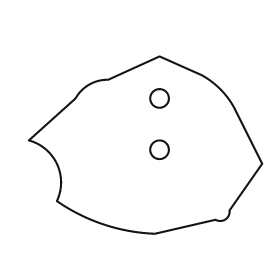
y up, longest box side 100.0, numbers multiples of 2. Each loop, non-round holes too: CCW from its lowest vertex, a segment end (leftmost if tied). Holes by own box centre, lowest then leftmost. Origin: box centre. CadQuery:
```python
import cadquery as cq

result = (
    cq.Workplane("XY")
    .moveTo(4.0, -38.0)
    .lineTo(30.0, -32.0)
    .threePointArc((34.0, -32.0), (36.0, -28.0))
    .lineTo(50.0, -8.0)
    .lineTo(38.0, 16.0)
    .threePointArc((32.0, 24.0), (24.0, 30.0))
    .lineTo(6.0, 38.0)
    .lineTo(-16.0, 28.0)
    .threePointArc((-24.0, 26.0), (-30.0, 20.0))
    .lineTo(-50.0, 2.0)
    .threePointArc((-38.0, -8.0), (-38.0, -24.0))
    .threePointArc((-18.0, -34.0), (4.0, -38.0))
    .close()
    .moveTo(6.0, -2.0)
    .circle(4.0)
    .moveTo(6.0, 20.0)
    .circle(4.0)
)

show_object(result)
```